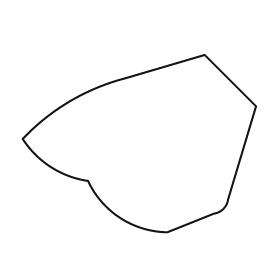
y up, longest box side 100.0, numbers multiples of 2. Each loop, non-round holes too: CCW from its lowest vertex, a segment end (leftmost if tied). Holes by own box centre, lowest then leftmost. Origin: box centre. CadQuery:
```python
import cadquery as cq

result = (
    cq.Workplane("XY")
    .moveTo(12.0, -38.0)
    .lineTo(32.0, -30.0)
    .threePointArc((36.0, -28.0), (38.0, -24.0))
    .lineTo(50.0, 16.0)
    .lineTo(28.0, 38.0)
    .lineTo(-6.0, 28.0)
    .threePointArc((-30.0, 18.0), (-50.0, 2.0))
    .threePointArc((-38.0, -10.0), (-22.0, -16.0))
    .threePointArc((-8.0, -32.0), (12.0, -38.0))
    .close()
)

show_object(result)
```